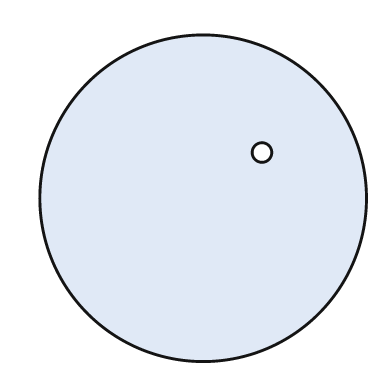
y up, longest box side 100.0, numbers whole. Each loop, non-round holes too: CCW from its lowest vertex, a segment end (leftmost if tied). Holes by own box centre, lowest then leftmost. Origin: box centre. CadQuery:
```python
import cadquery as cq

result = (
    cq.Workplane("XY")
    .moveTo(0.0, 0.0)
    .circle(50.0)
    .moveTo(18.0, 14.0)
    .circle(3.0)
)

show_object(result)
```